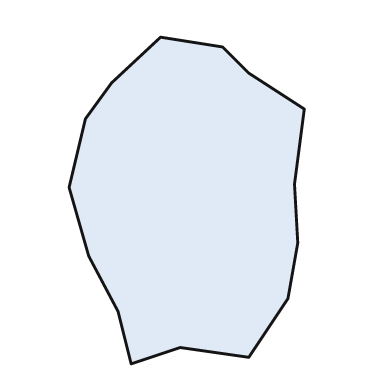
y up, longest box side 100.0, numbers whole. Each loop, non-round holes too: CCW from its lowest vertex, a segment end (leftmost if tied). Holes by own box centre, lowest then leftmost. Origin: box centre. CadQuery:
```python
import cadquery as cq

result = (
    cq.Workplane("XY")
    .moveTo(-17.0, -50.0)
    .lineTo(-2.0, -45.0)
    .lineTo(19.0, -48.0)
    .lineTo(31.0, -30.0)
    .lineTo(34.0, -13.0)
    .lineTo(33.0, 5.0)
    .lineTo(36.0, 28.0)
    .lineTo(19.0, 39.0)
    .lineTo(11.0, 47.0)
    .lineTo(-8.0, 50.0)
    .lineTo(-23.0, 36.0)
    .lineTo(-31.0, 25.0)
    .lineTo(-36.0, 4.0)
    .lineTo(-30.0, -17.0)
    .lineTo(-21.0, -34.0)
    .close()
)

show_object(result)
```